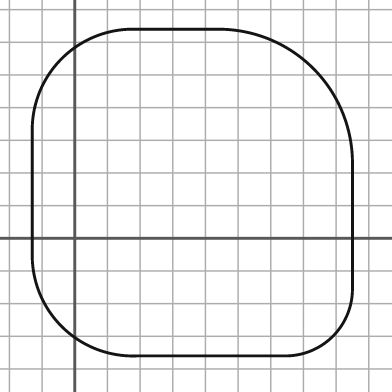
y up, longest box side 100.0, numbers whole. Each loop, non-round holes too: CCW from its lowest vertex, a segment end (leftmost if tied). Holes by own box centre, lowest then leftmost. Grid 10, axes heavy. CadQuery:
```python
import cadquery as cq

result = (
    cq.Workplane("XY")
    .moveTo(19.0, -36.0)
    .lineTo(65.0, -36.0)
    .threePointArc((79.0, -30.0), (85.0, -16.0))
    .lineTo(85.0, 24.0)
    .threePointArc((73.0, 52.0), (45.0, 64.0))
    .lineTo(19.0, 64.0)
    .threePointArc((-4.0, 55.0), (-13.0, 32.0))
    .lineTo(-13.0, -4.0)
    .threePointArc((-4.0, -27.0), (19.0, -36.0))
    .close()
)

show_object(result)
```